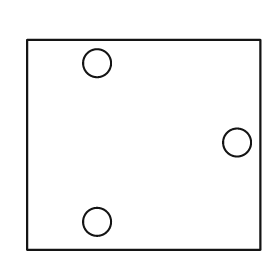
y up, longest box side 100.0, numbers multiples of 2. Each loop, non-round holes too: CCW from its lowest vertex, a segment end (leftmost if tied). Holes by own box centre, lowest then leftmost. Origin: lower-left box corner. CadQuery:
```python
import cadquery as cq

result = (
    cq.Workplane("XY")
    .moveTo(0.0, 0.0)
    .lineTo(100.0, 0.0)
    .lineTo(100.0, 90.0)
    .lineTo(0.0, 90.0)
    .close()
    .moveTo(30.0, 12.0)
    .circle(6.0)
    .moveTo(90.0, 46.0)
    .circle(6.0)
    .moveTo(30.0, 80.0)
    .circle(6.0)
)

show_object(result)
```